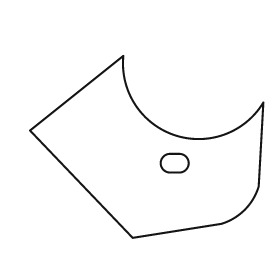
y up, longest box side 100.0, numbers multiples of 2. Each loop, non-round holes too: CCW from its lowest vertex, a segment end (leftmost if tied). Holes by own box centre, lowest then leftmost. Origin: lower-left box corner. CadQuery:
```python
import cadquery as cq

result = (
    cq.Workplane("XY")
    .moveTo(44.0, 0.0)
    .lineTo(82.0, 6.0)
    .threePointArc((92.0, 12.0), (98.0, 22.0))
    .lineTo(100.0, 58.0)
    .threePointArc((62.0, 44.0), (40.0, 78.0))
    .lineTo(0.0, 46.0)
    .close()
    .moveTo(60.0, 28.0)
    .lineTo(64.0, 28.0)
    .threePointArc((68.0, 32.0), (64.0, 36.0))
    .lineTo(60.0, 36.0)
    .threePointArc((56.0, 32.0), (60.0, 28.0))
    .close()
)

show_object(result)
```